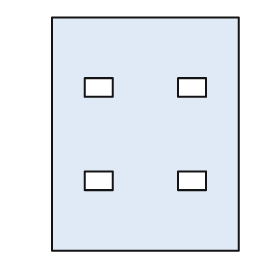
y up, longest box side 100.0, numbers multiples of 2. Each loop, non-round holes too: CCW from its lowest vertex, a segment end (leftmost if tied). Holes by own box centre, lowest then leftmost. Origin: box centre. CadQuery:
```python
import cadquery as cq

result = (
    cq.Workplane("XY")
    .moveTo(-40.0, -50.0)
    .lineTo(40.0, -50.0)
    .lineTo(40.0, 50.0)
    .lineTo(-40.0, 50.0)
    .close()
    .moveTo(-26.0, -24.0)
    .lineTo(-14.0, -24.0)
    .lineTo(-14.0, -16.0)
    .lineTo(-26.0, -16.0)
    .close()
    .moveTo(14.0, -24.0)
    .lineTo(26.0, -24.0)
    .lineTo(26.0, -16.0)
    .lineTo(14.0, -16.0)
    .close()
    .moveTo(-26.0, 16.0)
    .lineTo(-14.0, 16.0)
    .lineTo(-14.0, 24.0)
    .lineTo(-26.0, 24.0)
    .close()
    .moveTo(14.0, 16.0)
    .lineTo(26.0, 16.0)
    .lineTo(26.0, 24.0)
    .lineTo(14.0, 24.0)
    .close()
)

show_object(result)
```